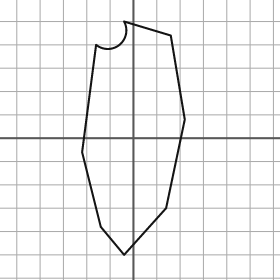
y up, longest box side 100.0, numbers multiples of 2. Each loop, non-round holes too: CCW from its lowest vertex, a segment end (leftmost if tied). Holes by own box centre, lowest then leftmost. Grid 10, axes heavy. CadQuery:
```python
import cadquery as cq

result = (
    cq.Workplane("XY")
    .moveTo(-4.0, -50.0)
    .lineTo(14.0, -30.0)
    .lineTo(22.0, 8.0)
    .lineTo(16.0, 44.0)
    .lineTo(-4.0, 50.0)
    .threePointArc((-6.0, 40.0), (-16.0, 40.0))
    .lineTo(-22.0, -6.0)
    .lineTo(-14.0, -38.0)
    .close()
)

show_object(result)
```